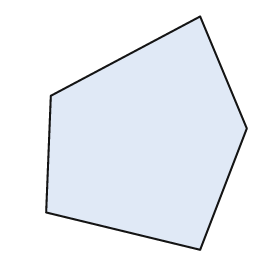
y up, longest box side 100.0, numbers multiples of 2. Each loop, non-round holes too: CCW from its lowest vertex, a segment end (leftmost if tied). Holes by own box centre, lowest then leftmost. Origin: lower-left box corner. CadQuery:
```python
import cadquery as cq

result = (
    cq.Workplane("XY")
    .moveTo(66.0, 0.0)
    .lineTo(86.0, 52.0)
    .lineTo(66.0, 100.0)
    .lineTo(2.0, 66.0)
    .lineTo(0.0, 16.0)
    .close()
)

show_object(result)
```